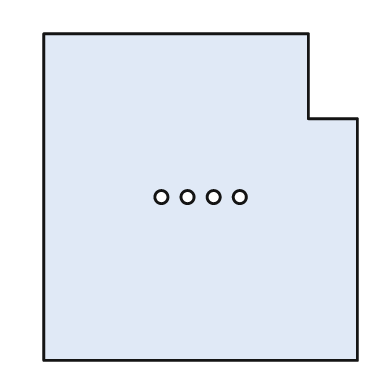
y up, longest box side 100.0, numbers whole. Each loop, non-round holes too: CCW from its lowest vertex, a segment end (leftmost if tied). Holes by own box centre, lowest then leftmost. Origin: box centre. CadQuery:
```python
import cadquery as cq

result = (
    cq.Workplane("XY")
    .moveTo(-48.0, -50.0)
    .lineTo(48.0, -50.0)
    .lineTo(48.0, 24.0)
    .lineTo(33.0, 24.0)
    .lineTo(33.0, 50.0)
    .lineTo(-48.0, 50.0)
    .close()
    .moveTo(-12.0, 0.0)
    .circle(2.0)
    .moveTo(-4.0, 0.0)
    .circle(2.0)
    .moveTo(4.0, 0.0)
    .circle(2.0)
    .moveTo(12.0, 0.0)
    .circle(2.0)
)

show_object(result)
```